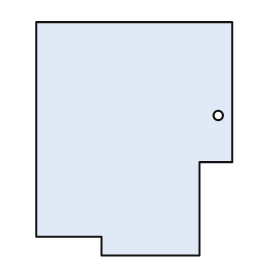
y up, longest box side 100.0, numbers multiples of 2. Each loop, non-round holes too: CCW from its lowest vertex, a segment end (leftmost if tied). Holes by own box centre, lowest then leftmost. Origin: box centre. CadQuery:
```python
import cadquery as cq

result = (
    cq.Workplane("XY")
    .moveTo(-14.0, -50.0)
    .lineTo(28.0, -50.0)
    .lineTo(28.0, -10.0)
    .lineTo(42.0, -10.0)
    .lineTo(42.0, 50.0)
    .lineTo(-42.0, 50.0)
    .lineTo(-42.0, -42.0)
    .lineTo(-14.0, -42.0)
    .close()
    .moveTo(36.0, 10.0)
    .circle(2.0)
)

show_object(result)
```